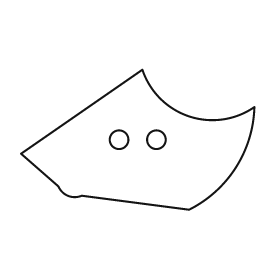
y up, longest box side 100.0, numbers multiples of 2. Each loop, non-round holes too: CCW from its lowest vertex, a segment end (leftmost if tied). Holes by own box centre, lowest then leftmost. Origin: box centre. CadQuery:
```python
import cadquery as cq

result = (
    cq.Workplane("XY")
    .moveTo(22.0, -30.0)
    .threePointArc((42.0, -12.0), (50.0, 14.0))
    .threePointArc((22.0, 10.0), (2.0, 30.0))
    .lineTo(-50.0, -6.0)
    .lineTo(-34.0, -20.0)
    .threePointArc((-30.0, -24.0), (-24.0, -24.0))
    .close()
    .moveTo(-8.0, 0.0)
    .circle(4.0)
    .moveTo(8.0, 0.0)
    .circle(4.0)
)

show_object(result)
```